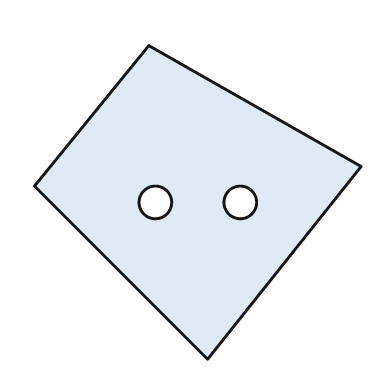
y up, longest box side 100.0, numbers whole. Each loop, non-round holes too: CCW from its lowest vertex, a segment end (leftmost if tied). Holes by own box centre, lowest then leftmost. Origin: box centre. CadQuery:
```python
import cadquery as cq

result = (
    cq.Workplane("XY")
    .moveTo(3.0, -48.0)
    .lineTo(50.0, 11.0)
    .lineTo(-15.0, 48.0)
    .lineTo(-50.0, 5.0)
    .close()
    .moveTo(-13.0, 0.0)
    .circle(5.0)
    .moveTo(13.0, 0.0)
    .circle(5.0)
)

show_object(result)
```